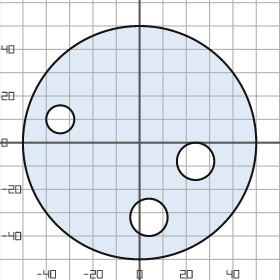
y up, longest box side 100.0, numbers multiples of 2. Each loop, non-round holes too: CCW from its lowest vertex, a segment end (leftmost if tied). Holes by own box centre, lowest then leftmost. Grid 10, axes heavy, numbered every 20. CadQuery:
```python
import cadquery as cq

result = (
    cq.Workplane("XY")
    .moveTo(0.0, 0.0)
    .circle(50.0)
    .moveTo(4.0, -32.0)
    .circle(8.0)
    .moveTo(24.0, -8.0)
    .circle(8.0)
    .moveTo(-34.0, 10.0)
    .circle(6.0)
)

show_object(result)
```